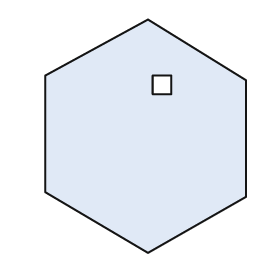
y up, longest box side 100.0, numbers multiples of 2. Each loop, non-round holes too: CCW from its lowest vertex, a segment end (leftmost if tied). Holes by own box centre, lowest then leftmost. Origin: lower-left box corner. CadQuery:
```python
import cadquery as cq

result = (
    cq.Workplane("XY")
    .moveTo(44.0, 0.0)
    .lineTo(86.0, 24.0)
    .lineTo(86.0, 74.0)
    .lineTo(44.0, 100.0)
    .lineTo(0.0, 76.0)
    .lineTo(0.0, 26.0)
    .close()
    .moveTo(46.0, 68.0)
    .lineTo(54.0, 68.0)
    .lineTo(54.0, 76.0)
    .lineTo(46.0, 76.0)
    .close()
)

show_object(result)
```